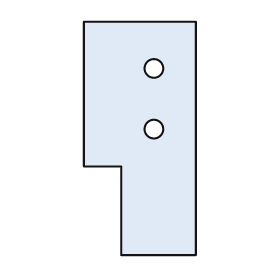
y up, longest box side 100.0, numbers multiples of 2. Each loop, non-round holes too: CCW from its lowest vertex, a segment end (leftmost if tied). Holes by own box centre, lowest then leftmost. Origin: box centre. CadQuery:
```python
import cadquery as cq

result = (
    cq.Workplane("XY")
    .moveTo(-8.0, -50.0)
    .lineTo(24.0, -50.0)
    .lineTo(24.0, 50.0)
    .lineTo(-24.0, 50.0)
    .lineTo(-24.0, -12.0)
    .lineTo(-8.0, -12.0)
    .close()
    .moveTo(6.0, 4.0)
    .circle(4.0)
    .moveTo(6.0, 30.0)
    .circle(4.0)
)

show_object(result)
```